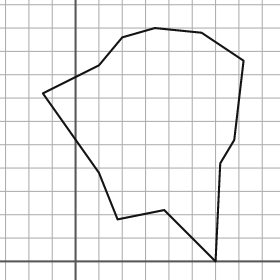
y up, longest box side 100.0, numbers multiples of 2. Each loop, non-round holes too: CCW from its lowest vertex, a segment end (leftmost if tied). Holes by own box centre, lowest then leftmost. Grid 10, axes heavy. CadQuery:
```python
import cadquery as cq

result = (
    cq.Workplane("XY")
    .moveTo(60.0, 0.0)
    .lineTo(62.0, 42.0)
    .lineTo(68.0, 52.0)
    .lineTo(72.0, 86.0)
    .lineTo(54.0, 98.0)
    .lineTo(34.0, 100.0)
    .lineTo(20.0, 96.0)
    .lineTo(10.0, 84.0)
    .lineTo(-14.0, 72.0)
    .lineTo(10.0, 38.0)
    .lineTo(18.0, 18.0)
    .lineTo(38.0, 22.0)
    .close()
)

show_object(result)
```